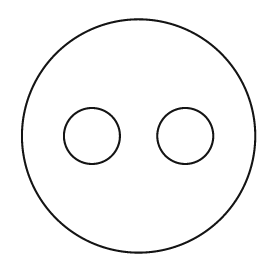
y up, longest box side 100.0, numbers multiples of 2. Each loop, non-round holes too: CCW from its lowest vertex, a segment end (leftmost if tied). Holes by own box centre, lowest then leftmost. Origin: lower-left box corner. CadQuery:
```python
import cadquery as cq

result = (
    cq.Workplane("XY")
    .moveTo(50.0, 50.0)
    .circle(50.0)
    .moveTo(30.0, 50.0)
    .circle(12.0)
    .moveTo(70.0, 50.0)
    .circle(12.0)
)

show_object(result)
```